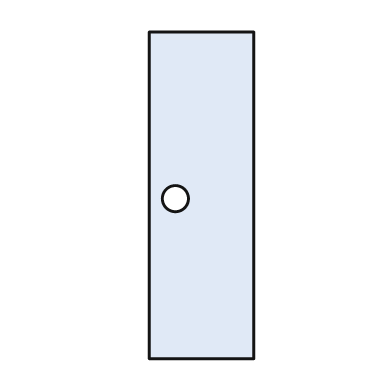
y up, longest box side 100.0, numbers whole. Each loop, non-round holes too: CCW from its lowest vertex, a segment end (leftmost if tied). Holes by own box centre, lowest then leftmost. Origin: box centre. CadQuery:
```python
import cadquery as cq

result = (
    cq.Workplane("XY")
    .moveTo(-16.0, -50.0)
    .lineTo(16.0, -50.0)
    .lineTo(16.0, 50.0)
    .lineTo(-16.0, 50.0)
    .close()
    .moveTo(-8.0, -1.0)
    .circle(4.0)
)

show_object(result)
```